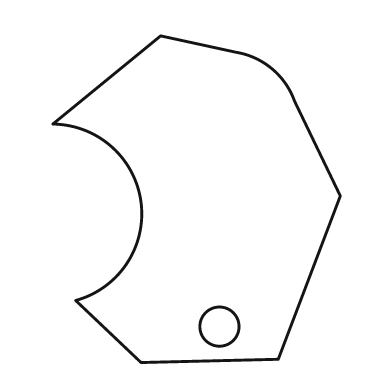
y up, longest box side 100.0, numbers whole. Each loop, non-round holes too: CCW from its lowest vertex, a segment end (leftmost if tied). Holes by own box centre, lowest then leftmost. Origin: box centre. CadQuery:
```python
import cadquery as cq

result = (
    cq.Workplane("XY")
    .moveTo(-17.0, -50.0)
    .lineTo(25.0, -49.0)
    .lineTo(44.0, 1.0)
    .lineTo(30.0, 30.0)
    .threePointArc((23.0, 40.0), (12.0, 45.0))
    .lineTo(-11.0, 50.0)
    .lineTo(-44.0, 23.0)
    .threePointArc((-17.0, -1.0), (-37.0, -31.0))
    .close()
    .moveTo(7.0, -39.0)
    .circle(6.0)
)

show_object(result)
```